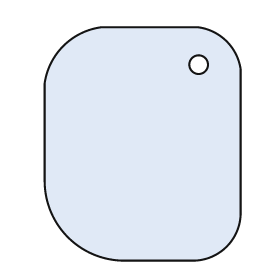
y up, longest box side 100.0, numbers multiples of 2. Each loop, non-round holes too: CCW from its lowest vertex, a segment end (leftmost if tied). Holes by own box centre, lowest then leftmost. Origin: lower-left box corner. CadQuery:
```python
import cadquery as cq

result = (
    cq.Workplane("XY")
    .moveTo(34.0, 0.0)
    .lineTo(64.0, 0.0)
    .threePointArc((78.0, 6.0), (84.0, 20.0))
    .lineTo(84.0, 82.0)
    .threePointArc((78.0, 94.0), (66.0, 100.0))
    .lineTo(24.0, 100.0)
    .threePointArc((8.0, 92.0), (0.0, 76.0))
    .lineTo(0.0, 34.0)
    .threePointArc((10.0, 10.0), (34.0, 0.0))
    .close()
    .moveTo(66.0, 84.0)
    .circle(4.0)
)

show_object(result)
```